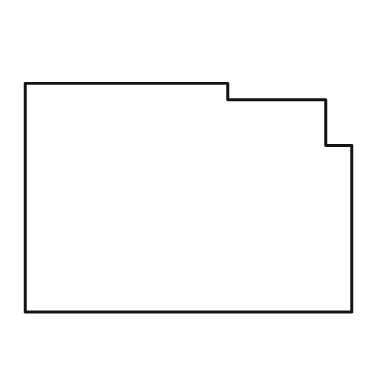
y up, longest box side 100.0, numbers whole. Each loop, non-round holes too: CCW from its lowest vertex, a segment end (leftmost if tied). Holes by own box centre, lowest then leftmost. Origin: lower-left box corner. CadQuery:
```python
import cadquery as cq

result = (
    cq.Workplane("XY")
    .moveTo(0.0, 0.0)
    .lineTo(100.0, 0.0)
    .lineTo(100.0, 51.0)
    .lineTo(92.0, 51.0)
    .lineTo(92.0, 65.0)
    .lineTo(62.0, 65.0)
    .lineTo(62.0, 70.0)
    .lineTo(0.0, 70.0)
    .close()
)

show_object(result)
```